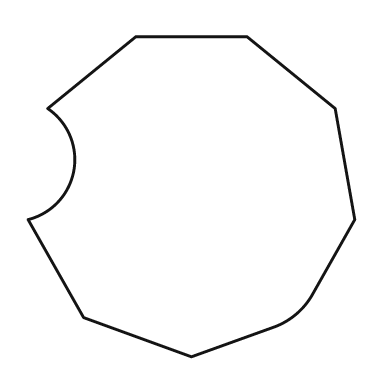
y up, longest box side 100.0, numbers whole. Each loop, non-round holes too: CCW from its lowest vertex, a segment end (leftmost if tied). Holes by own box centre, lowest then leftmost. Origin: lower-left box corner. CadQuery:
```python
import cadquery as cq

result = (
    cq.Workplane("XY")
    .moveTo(50.0, 0.0)
    .lineTo(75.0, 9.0)
    .threePointArc((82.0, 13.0), (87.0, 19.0))
    .lineTo(100.0, 42.0)
    .lineTo(94.0, 76.0)
    .lineTo(67.0, 98.0)
    .lineTo(33.0, 98.0)
    .lineTo(6.0, 76.0)
    .threePointArc((14.0, 57.0), (0.0, 42.0))
    .lineTo(17.0, 12.0)
    .close()
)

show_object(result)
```